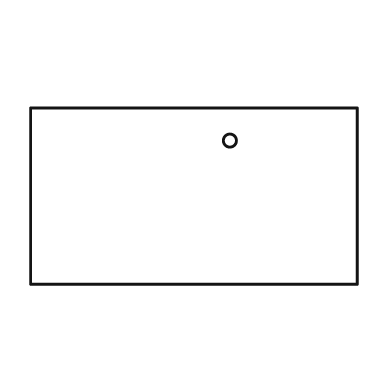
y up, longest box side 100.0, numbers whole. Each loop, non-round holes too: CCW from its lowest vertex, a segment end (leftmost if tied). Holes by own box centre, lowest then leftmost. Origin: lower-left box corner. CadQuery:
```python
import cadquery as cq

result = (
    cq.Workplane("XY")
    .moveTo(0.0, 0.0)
    .lineTo(100.0, 0.0)
    .lineTo(100.0, 54.0)
    .lineTo(0.0, 54.0)
    .close()
    .moveTo(61.0, 44.0)
    .circle(2.0)
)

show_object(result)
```